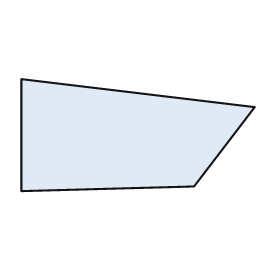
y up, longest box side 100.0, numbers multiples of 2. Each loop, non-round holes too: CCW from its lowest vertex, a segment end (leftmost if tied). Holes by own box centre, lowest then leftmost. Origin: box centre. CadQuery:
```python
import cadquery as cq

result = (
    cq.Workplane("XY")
    .moveTo(-50.0, -24.0)
    .lineTo(24.0, -22.0)
    .lineTo(50.0, 12.0)
    .lineTo(-50.0, 24.0)
    .close()
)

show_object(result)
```